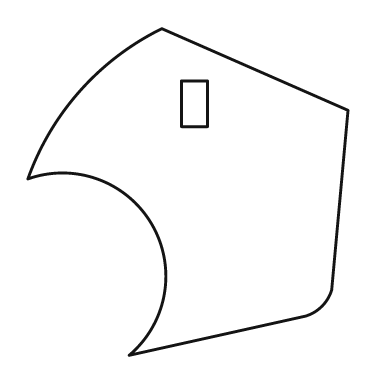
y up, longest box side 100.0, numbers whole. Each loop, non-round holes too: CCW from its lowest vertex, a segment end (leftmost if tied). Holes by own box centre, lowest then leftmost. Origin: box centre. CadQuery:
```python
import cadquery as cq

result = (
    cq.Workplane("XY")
    .moveTo(-18.0, -50.0)
    .lineTo(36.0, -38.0)
    .threePointArc((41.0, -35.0), (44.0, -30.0))
    .lineTo(49.0, 25.0)
    .lineTo(-8.0, 50.0)
    .threePointArc((-33.0, 31.0), (-49.0, 4.0))
    .threePointArc((-11.0, -10.0), (-18.0, -50.0))
    .close()
    .moveTo(-2.0, 20.0)
    .lineTo(6.0, 20.0)
    .lineTo(6.0, 34.0)
    .lineTo(-2.0, 34.0)
    .close()
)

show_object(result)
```